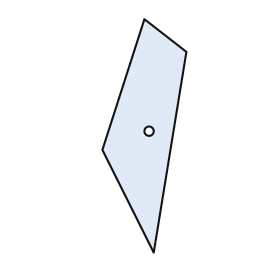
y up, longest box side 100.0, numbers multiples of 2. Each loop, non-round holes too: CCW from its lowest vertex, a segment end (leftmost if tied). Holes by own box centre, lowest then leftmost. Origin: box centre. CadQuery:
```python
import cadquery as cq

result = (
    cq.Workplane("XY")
    .moveTo(4.0, -50.0)
    .lineTo(18.0, 36.0)
    .lineTo(0.0, 50.0)
    .lineTo(-18.0, -6.0)
    .close()
    .moveTo(2.0, 2.0)
    .circle(2.0)
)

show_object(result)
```